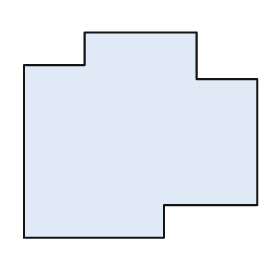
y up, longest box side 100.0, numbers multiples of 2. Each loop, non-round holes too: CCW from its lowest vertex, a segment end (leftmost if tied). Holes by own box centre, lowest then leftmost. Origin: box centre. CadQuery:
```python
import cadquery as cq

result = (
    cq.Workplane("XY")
    .moveTo(-50.0, -44.0)
    .lineTo(10.0, -44.0)
    .lineTo(10.0, -30.0)
    .lineTo(50.0, -30.0)
    .lineTo(50.0, 24.0)
    .lineTo(24.0, 24.0)
    .lineTo(24.0, 44.0)
    .lineTo(-24.0, 44.0)
    .lineTo(-24.0, 30.0)
    .lineTo(-50.0, 30.0)
    .close()
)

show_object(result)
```